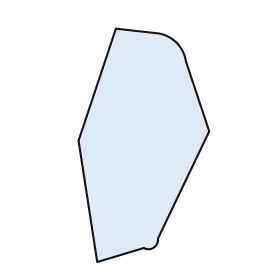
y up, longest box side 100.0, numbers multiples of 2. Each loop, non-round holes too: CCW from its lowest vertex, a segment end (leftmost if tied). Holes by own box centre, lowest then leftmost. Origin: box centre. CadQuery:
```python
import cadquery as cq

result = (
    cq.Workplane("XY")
    .moveTo(-20.0, -50.0)
    .lineTo(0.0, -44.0)
    .threePointArc((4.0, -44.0), (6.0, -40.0))
    .lineTo(28.0, 6.0)
    .lineTo(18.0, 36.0)
    .threePointArc((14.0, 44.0), (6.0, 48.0))
    .lineTo(-12.0, 50.0)
    .lineTo(-28.0, 2.0)
    .close()
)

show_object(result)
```